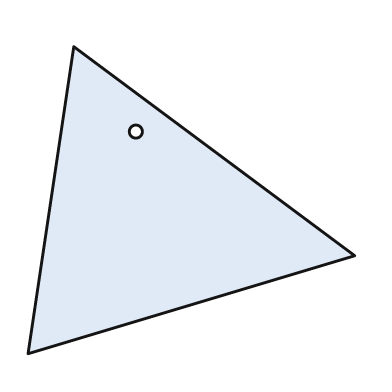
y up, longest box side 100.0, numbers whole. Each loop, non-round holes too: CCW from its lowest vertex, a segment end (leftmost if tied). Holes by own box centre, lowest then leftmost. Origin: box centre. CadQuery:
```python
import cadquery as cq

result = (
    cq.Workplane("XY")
    .moveTo(-50.0, -47.0)
    .lineTo(50.0, -17.0)
    .lineTo(-36.0, 47.0)
    .close()
    .moveTo(-17.0, 21.0)
    .circle(2.0)
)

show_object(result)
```